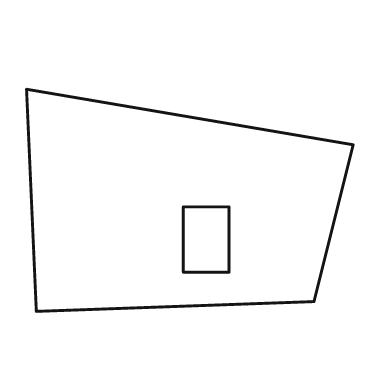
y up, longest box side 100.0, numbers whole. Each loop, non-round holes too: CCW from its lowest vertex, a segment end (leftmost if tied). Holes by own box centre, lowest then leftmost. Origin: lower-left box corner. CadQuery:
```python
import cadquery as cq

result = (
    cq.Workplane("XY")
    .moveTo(3.0, 0.0)
    .lineTo(88.0, 3.0)
    .lineTo(100.0, 51.0)
    .lineTo(0.0, 68.0)
    .close()
    .moveTo(48.0, 12.0)
    .lineTo(62.0, 12.0)
    .lineTo(62.0, 32.0)
    .lineTo(48.0, 32.0)
    .close()
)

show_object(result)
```